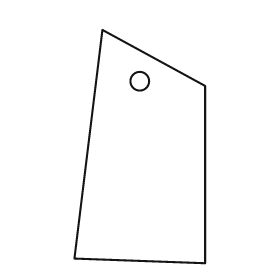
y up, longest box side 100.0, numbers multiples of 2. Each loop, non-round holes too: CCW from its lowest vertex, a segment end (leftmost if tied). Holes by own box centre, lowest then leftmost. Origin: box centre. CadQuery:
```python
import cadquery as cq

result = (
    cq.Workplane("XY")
    .moveTo(28.0, -50.0)
    .lineTo(28.0, 26.0)
    .lineTo(-16.0, 50.0)
    .lineTo(-28.0, -48.0)
    .close()
    .moveTo(0.0, 28.0)
    .circle(4.0)
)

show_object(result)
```